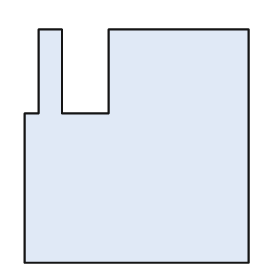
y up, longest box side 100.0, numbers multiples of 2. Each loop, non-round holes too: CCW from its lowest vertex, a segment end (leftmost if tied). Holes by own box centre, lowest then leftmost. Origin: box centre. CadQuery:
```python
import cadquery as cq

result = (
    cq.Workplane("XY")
    .moveTo(-48.0, -50.0)
    .lineTo(48.0, -50.0)
    .lineTo(48.0, 50.0)
    .lineTo(-12.0, 50.0)
    .lineTo(-12.0, 14.0)
    .lineTo(-32.0, 14.0)
    .lineTo(-32.0, 50.0)
    .lineTo(-42.0, 50.0)
    .lineTo(-42.0, 14.0)
    .lineTo(-48.0, 14.0)
    .close()
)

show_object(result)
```